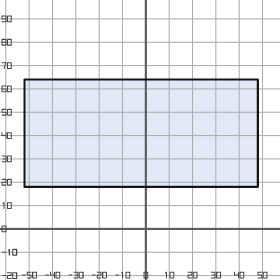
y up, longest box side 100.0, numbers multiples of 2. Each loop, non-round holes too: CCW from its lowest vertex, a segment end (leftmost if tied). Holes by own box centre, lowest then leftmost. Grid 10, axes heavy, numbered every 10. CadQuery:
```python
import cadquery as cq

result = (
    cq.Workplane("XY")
    .moveTo(-52.0, 18.0)
    .lineTo(48.0, 18.0)
    .lineTo(48.0, 64.0)
    .lineTo(-52.0, 64.0)
    .close()
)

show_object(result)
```